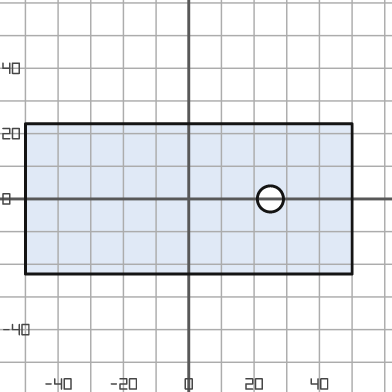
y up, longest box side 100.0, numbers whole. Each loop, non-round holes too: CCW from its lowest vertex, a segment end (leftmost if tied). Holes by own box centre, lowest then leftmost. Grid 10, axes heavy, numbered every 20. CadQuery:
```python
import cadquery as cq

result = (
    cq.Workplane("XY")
    .moveTo(-50.0, -23.0)
    .lineTo(50.0, -23.0)
    .lineTo(50.0, 23.0)
    .lineTo(-50.0, 23.0)
    .close()
    .moveTo(25.0, 0.0)
    .circle(4.0)
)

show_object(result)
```